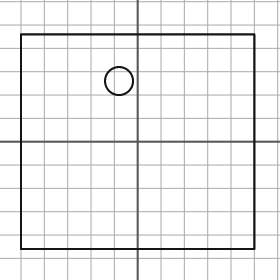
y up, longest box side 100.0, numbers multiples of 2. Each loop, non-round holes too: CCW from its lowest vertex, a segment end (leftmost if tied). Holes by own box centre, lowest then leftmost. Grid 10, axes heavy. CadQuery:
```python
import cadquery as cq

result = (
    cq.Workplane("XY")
    .moveTo(-50.0, -46.0)
    .lineTo(50.0, -46.0)
    .lineTo(50.0, 46.0)
    .lineTo(-50.0, 46.0)
    .close()
    .moveTo(-8.0, 26.0)
    .circle(6.0)
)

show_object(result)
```